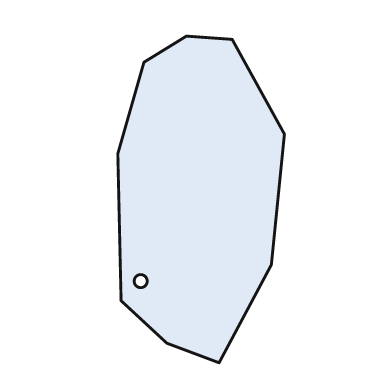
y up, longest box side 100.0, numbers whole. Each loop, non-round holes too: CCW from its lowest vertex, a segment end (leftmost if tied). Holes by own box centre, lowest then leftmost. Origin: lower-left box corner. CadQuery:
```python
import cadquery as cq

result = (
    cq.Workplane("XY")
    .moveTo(31.0, 0.0)
    .lineTo(47.0, 30.0)
    .lineTo(51.0, 70.0)
    .lineTo(35.0, 99.0)
    .lineTo(21.0, 100.0)
    .lineTo(8.0, 92.0)
    .lineTo(0.0, 64.0)
    .lineTo(1.0, 19.0)
    .lineTo(15.0, 6.0)
    .close()
    .moveTo(7.0, 25.0)
    .circle(2.0)
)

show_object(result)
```